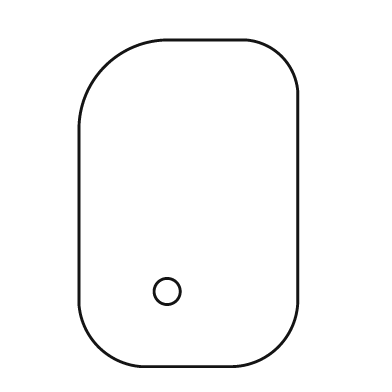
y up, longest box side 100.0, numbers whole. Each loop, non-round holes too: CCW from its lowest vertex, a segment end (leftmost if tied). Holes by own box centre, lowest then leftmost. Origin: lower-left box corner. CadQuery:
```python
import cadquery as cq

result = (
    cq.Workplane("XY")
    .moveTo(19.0, 0.0)
    .lineTo(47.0, 0.0)
    .threePointArc((61.0, 6.0), (67.0, 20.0))
    .lineTo(67.0, 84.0)
    .threePointArc((62.0, 95.0), (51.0, 100.0))
    .lineTo(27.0, 100.0)
    .threePointArc((8.0, 92.0), (0.0, 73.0))
    .lineTo(0.0, 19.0)
    .threePointArc((6.0, 6.0), (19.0, 0.0))
    .close()
    .moveTo(27.0, 23.0)
    .circle(4.0)
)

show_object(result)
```